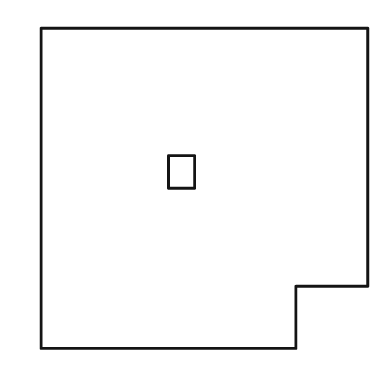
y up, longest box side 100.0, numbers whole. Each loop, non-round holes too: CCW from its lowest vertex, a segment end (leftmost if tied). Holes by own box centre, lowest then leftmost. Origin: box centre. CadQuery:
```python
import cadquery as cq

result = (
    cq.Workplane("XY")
    .moveTo(-50.0, -49.0)
    .lineTo(28.0, -49.0)
    .lineTo(28.0, -30.0)
    .lineTo(50.0, -30.0)
    .lineTo(50.0, 49.0)
    .lineTo(-50.0, 49.0)
    .close()
    .moveTo(-11.0, 0.0)
    .lineTo(-3.0, 0.0)
    .lineTo(-3.0, 10.0)
    .lineTo(-11.0, 10.0)
    .close()
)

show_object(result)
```